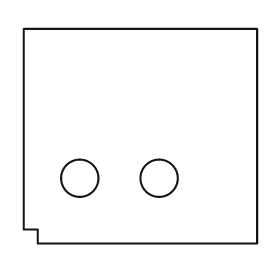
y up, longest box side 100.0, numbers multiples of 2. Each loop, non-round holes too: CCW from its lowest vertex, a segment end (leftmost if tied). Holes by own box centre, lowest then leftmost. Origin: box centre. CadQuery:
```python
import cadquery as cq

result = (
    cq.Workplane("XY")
    .moveTo(-44.0, -46.0)
    .lineTo(50.0, -46.0)
    .lineTo(50.0, 46.0)
    .lineTo(-50.0, 46.0)
    .lineTo(-50.0, -40.0)
    .lineTo(-44.0, -40.0)
    .close()
    .moveTo(-26.0, -18.0)
    .circle(8.0)
    .moveTo(8.0, -18.0)
    .circle(8.0)
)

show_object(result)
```